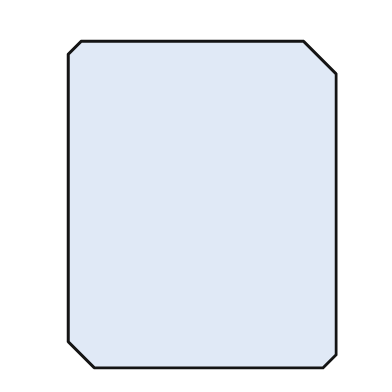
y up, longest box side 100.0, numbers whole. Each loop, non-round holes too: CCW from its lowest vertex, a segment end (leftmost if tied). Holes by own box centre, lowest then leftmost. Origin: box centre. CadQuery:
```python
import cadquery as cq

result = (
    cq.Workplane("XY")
    .moveTo(-33.0, -50.0)
    .lineTo(37.0, -50.0)
    .lineTo(41.0, -46.0)
    .lineTo(41.0, 40.0)
    .lineTo(31.0, 50.0)
    .lineTo(-37.0, 50.0)
    .lineTo(-41.0, 46.0)
    .lineTo(-41.0, -42.0)
    .close()
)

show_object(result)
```